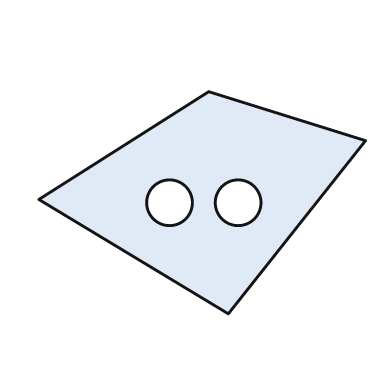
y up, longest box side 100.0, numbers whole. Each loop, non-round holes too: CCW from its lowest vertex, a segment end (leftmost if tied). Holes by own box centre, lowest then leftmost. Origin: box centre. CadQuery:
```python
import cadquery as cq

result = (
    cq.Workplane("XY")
    .moveTo(8.0, -34.0)
    .lineTo(50.0, 19.0)
    .lineTo(2.0, 34.0)
    .lineTo(-50.0, 1.0)
    .close()
    .moveTo(-10.0, 0.0)
    .circle(7.0)
    .moveTo(11.0, 0.0)
    .circle(7.0)
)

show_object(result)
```